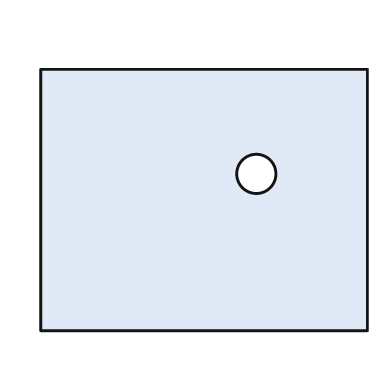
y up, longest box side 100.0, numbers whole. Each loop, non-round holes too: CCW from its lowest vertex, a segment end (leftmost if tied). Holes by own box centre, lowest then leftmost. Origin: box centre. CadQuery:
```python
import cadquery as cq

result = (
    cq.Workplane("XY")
    .moveTo(-50.0, -40.0)
    .lineTo(50.0, -40.0)
    .lineTo(50.0, 40.0)
    .lineTo(-50.0, 40.0)
    .close()
    .moveTo(16.0, 8.0)
    .circle(6.0)
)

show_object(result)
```